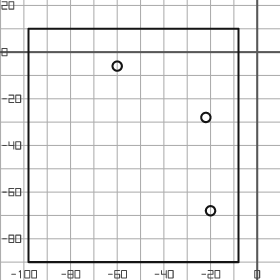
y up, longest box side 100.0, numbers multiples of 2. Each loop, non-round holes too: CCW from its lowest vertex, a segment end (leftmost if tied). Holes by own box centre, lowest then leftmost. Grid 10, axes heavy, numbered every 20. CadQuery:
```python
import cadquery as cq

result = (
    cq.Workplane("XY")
    .moveTo(-98.0, -90.0)
    .lineTo(-8.0, -90.0)
    .lineTo(-8.0, 10.0)
    .lineTo(-98.0, 10.0)
    .close()
    .moveTo(-20.0, -68.0)
    .circle(2.0)
    .moveTo(-22.0, -28.0)
    .circle(2.0)
    .moveTo(-60.0, -6.0)
    .circle(2.0)
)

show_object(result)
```